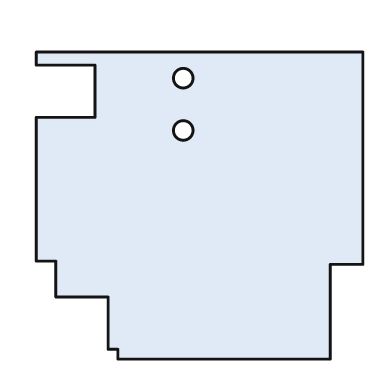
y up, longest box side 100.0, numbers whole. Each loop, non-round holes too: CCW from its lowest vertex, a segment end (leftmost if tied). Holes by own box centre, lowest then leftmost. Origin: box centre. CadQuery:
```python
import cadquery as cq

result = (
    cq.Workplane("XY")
    .moveTo(-25.0, -47.0)
    .lineTo(40.0, -47.0)
    .lineTo(40.0, -18.0)
    .lineTo(50.0, -18.0)
    .lineTo(50.0, 47.0)
    .lineTo(-50.0, 47.0)
    .lineTo(-50.0, 43.0)
    .lineTo(-32.0, 43.0)
    .lineTo(-32.0, 27.0)
    .lineTo(-50.0, 27.0)
    .lineTo(-50.0, -17.0)
    .lineTo(-44.0, -17.0)
    .lineTo(-44.0, -28.0)
    .lineTo(-28.0, -28.0)
    .lineTo(-28.0, -44.0)
    .lineTo(-25.0, -44.0)
    .close()
    .moveTo(-5.0, 23.0)
    .circle(3.0)
    .moveTo(-5.0, 39.0)
    .circle(3.0)
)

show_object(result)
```